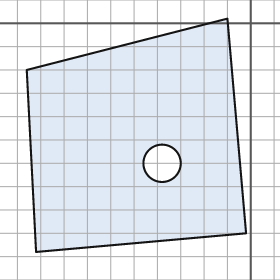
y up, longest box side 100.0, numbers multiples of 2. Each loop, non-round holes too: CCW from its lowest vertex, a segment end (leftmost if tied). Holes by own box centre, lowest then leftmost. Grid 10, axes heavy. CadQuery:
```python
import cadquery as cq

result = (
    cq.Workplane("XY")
    .moveTo(-92.0, -98.0)
    .lineTo(-2.0, -90.0)
    .lineTo(-10.0, 2.0)
    .lineTo(-96.0, -20.0)
    .close()
    .moveTo(-38.0, -60.0)
    .circle(8.0)
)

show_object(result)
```